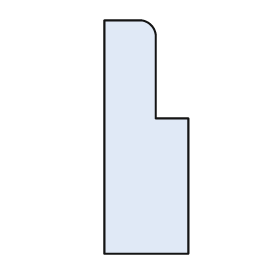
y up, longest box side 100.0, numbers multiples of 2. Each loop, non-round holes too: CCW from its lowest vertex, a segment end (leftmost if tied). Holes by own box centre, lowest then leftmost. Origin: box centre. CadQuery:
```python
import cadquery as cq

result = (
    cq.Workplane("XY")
    .moveTo(-18.0, -50.0)
    .lineTo(18.0, -50.0)
    .lineTo(18.0, 8.0)
    .lineTo(4.0, 8.0)
    .lineTo(4.0, 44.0)
    .threePointArc((2.0, 48.0), (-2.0, 50.0))
    .lineTo(-18.0, 50.0)
    .close()
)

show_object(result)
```